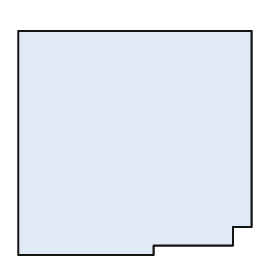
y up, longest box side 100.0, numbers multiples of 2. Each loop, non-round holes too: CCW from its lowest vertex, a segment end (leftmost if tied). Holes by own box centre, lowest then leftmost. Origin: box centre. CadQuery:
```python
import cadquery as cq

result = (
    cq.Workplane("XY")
    .moveTo(-50.0, -48.0)
    .lineTo(8.0, -48.0)
    .lineTo(8.0, -44.0)
    .lineTo(42.0, -44.0)
    .lineTo(42.0, -36.0)
    .lineTo(50.0, -36.0)
    .lineTo(50.0, 48.0)
    .lineTo(-50.0, 48.0)
    .close()
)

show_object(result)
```